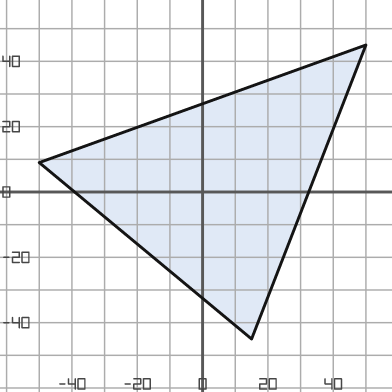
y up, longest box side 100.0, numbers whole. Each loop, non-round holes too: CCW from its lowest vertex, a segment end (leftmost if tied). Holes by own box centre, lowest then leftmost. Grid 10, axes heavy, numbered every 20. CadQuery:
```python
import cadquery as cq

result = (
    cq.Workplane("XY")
    .moveTo(15.0, -45.0)
    .lineTo(50.0, 45.0)
    .lineTo(-50.0, 9.0)
    .close()
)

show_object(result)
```